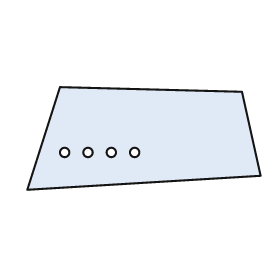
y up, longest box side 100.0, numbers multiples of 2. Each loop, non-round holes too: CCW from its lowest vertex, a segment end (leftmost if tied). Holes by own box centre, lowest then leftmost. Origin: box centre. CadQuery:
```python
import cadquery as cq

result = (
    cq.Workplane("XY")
    .moveTo(-50.0, -22.0)
    .lineTo(50.0, -16.0)
    .lineTo(42.0, 20.0)
    .lineTo(-36.0, 22.0)
    .close()
    .moveTo(-34.0, -6.0)
    .circle(2.0)
    .moveTo(-24.0, -6.0)
    .circle(2.0)
    .moveTo(-14.0, -6.0)
    .circle(2.0)
    .moveTo(-4.0, -6.0)
    .circle(2.0)
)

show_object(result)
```